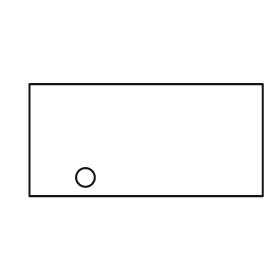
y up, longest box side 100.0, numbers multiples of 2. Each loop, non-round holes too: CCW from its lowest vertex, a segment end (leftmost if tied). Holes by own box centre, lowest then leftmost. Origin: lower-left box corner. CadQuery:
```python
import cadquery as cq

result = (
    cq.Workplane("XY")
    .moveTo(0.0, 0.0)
    .lineTo(100.0, 0.0)
    .lineTo(100.0, 48.0)
    .lineTo(0.0, 48.0)
    .close()
    .moveTo(24.0, 8.0)
    .circle(4.0)
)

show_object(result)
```